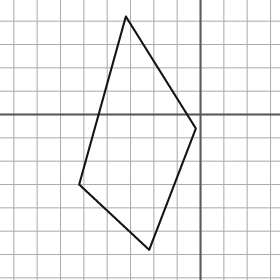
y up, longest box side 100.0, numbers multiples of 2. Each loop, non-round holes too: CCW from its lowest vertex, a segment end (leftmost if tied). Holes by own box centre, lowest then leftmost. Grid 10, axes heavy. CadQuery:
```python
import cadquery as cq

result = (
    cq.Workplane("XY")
    .moveTo(-22.0, -58.0)
    .lineTo(-2.0, -6.0)
    .lineTo(-32.0, 42.0)
    .lineTo(-52.0, -30.0)
    .close()
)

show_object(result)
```